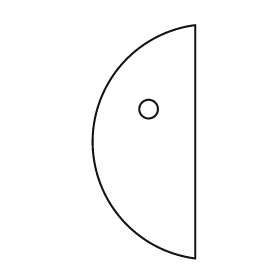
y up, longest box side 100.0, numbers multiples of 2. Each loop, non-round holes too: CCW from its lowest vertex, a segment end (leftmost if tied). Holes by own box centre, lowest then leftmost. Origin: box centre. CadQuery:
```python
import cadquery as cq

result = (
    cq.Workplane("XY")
    .moveTo(22.0, -50.0)
    .lineTo(22.0, 50.0)
    .threePointArc((-22.0, 0.0), (22.0, -50.0))
    .close()
    .moveTo(2.0, 14.0)
    .circle(4.0)
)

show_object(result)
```